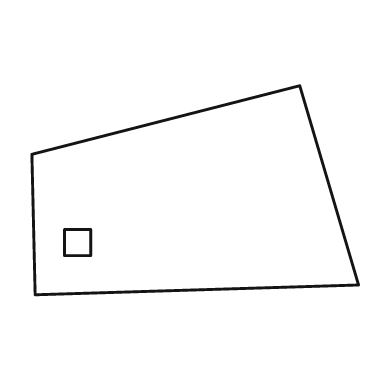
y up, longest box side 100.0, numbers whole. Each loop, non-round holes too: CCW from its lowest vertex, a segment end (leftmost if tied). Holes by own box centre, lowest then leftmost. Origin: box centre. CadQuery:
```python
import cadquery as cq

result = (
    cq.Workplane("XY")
    .moveTo(-49.0, -32.0)
    .lineTo(50.0, -29.0)
    .lineTo(32.0, 32.0)
    .lineTo(-50.0, 11.0)
    .close()
    .moveTo(-40.0, -20.0)
    .lineTo(-32.0, -20.0)
    .lineTo(-32.0, -12.0)
    .lineTo(-40.0, -12.0)
    .close()
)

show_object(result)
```